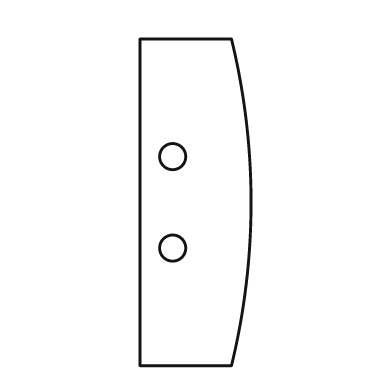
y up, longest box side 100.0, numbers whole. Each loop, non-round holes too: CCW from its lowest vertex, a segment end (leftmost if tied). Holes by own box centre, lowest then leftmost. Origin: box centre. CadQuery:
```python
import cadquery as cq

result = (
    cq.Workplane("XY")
    .moveTo(-17.0, -50.0)
    .lineTo(11.0, -50.0)
    .threePointArc((17.0, 0.0), (11.0, 50.0))
    .lineTo(-17.0, 50.0)
    .close()
    .moveTo(-7.0, -14.0)
    .circle(4.0)
    .moveTo(-7.0, 14.0)
    .circle(4.0)
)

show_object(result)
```